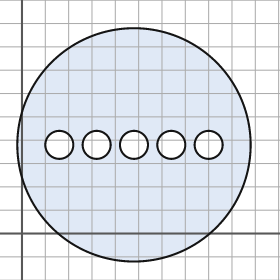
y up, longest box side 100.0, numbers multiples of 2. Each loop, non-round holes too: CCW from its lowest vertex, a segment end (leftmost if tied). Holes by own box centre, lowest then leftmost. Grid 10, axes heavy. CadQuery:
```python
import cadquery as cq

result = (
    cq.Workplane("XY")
    .moveTo(48.0, 38.0)
    .circle(50.0)
    .moveTo(16.0, 38.0)
    .circle(6.0)
    .moveTo(32.0, 38.0)
    .circle(6.0)
    .moveTo(48.0, 38.0)
    .circle(6.0)
    .moveTo(64.0, 38.0)
    .circle(6.0)
    .moveTo(80.0, 38.0)
    .circle(6.0)
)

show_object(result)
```